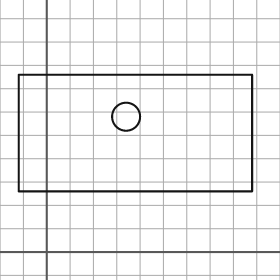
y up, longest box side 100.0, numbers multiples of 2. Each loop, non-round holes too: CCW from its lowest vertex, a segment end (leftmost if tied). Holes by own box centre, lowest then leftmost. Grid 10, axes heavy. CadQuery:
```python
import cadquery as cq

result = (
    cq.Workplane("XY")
    .moveTo(-12.0, 26.0)
    .lineTo(88.0, 26.0)
    .lineTo(88.0, 76.0)
    .lineTo(-12.0, 76.0)
    .close()
    .moveTo(34.0, 58.0)
    .circle(6.0)
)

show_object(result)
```